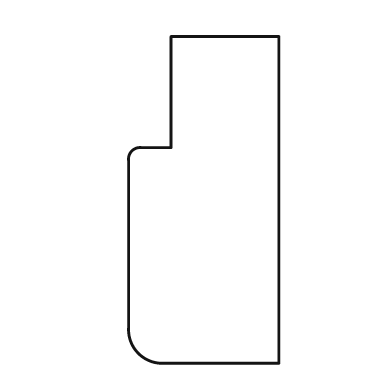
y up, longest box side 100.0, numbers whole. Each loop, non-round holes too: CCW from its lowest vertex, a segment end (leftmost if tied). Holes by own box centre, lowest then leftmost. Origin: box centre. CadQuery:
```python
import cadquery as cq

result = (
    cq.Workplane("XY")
    .moveTo(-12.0, -50.0)
    .lineTo(23.0, -50.0)
    .lineTo(23.0, 50.0)
    .lineTo(-10.0, 50.0)
    .lineTo(-10.0, 16.0)
    .lineTo(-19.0, 16.0)
    .threePointArc((-22.0, 15.0), (-23.0, 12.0))
    .lineTo(-23.0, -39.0)
    .threePointArc((-20.0, -47.0), (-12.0, -50.0))
    .close()
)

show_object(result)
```